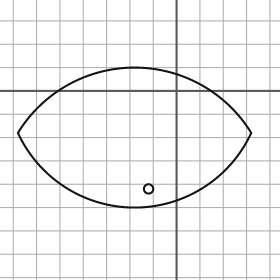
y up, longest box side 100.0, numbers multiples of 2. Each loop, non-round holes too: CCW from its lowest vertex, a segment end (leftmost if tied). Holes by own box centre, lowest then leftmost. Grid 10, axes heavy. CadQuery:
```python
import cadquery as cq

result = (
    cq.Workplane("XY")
    .moveTo(-68.0, -18.0)
    .threePointArc((-18.0, -50.0), (32.0, -18.0))
    .threePointArc((-18.0, 10.0), (-68.0, -18.0))
    .close()
    .moveTo(-12.0, -42.0)
    .circle(2.0)
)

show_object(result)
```